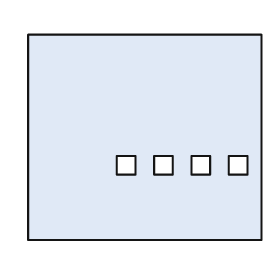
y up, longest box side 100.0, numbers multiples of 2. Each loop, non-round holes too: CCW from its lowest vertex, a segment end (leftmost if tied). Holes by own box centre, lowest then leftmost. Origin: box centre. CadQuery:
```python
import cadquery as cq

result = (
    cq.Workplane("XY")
    .moveTo(-50.0, -44.0)
    .lineTo(50.0, -44.0)
    .lineTo(50.0, 44.0)
    .lineTo(-50.0, 44.0)
    .close()
    .moveTo(-12.0, -16.0)
    .lineTo(-4.0, -16.0)
    .lineTo(-4.0, -8.0)
    .lineTo(-12.0, -8.0)
    .close()
    .moveTo(4.0, -16.0)
    .lineTo(12.0, -16.0)
    .lineTo(12.0, -8.0)
    .lineTo(4.0, -8.0)
    .close()
    .moveTo(20.0, -16.0)
    .lineTo(28.0, -16.0)
    .lineTo(28.0, -8.0)
    .lineTo(20.0, -8.0)
    .close()
    .moveTo(36.0, -16.0)
    .lineTo(44.0, -16.0)
    .lineTo(44.0, -8.0)
    .lineTo(36.0, -8.0)
    .close()
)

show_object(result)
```